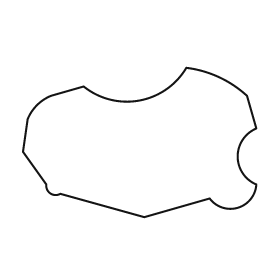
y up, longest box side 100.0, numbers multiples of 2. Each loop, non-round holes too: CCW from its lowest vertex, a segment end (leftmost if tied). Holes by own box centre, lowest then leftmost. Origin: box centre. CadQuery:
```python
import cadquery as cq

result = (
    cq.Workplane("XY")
    .moveTo(2.0, -32.0)
    .lineTo(30.0, -24.0)
    .threePointArc((42.0, -28.0), (50.0, -18.0))
    .threePointArc((42.0, -6.0), (50.0, 6.0))
    .lineTo(46.0, 20.0)
    .threePointArc((34.0, 28.0), (20.0, 32.0))
    .threePointArc((0.0, 18.0), (-24.0, 24.0))
    .lineTo(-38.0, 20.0)
    .threePointArc((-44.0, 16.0), (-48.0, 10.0))
    .lineTo(-50.0, -4.0)
    .lineTo(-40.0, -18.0)
    .threePointArc((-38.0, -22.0), (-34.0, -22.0))
    .close()
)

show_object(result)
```